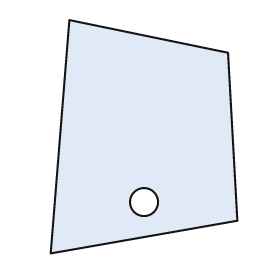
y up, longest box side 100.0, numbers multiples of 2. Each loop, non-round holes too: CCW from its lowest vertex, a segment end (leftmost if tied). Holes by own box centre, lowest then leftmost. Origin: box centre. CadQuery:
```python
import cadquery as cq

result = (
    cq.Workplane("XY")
    .moveTo(-40.0, -50.0)
    .lineTo(40.0, -36.0)
    .lineTo(36.0, 36.0)
    .lineTo(-32.0, 50.0)
    .close()
    .moveTo(0.0, -28.0)
    .circle(6.0)
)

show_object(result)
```